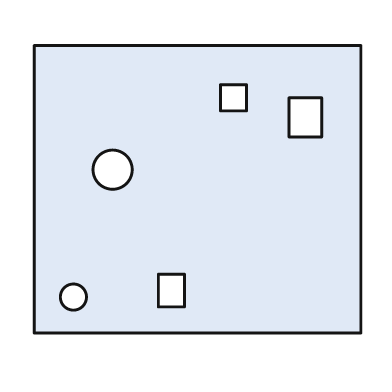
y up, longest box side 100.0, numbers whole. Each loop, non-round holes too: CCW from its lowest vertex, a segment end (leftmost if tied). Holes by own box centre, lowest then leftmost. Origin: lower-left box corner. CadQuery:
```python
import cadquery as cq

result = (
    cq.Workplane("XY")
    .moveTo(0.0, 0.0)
    .lineTo(100.0, 0.0)
    .lineTo(100.0, 88.0)
    .lineTo(0.0, 88.0)
    .close()
    .moveTo(12.0, 11.0)
    .circle(4.0)
    .moveTo(38.0, 8.0)
    .lineTo(46.0, 8.0)
    .lineTo(46.0, 18.0)
    .lineTo(38.0, 18.0)
    .close()
    .moveTo(24.0, 50.0)
    .circle(6.0)
    .moveTo(78.0, 60.0)
    .lineTo(88.0, 60.0)
    .lineTo(88.0, 72.0)
    .lineTo(78.0, 72.0)
    .close()
    .moveTo(57.0, 68.0)
    .lineTo(65.0, 68.0)
    .lineTo(65.0, 76.0)
    .lineTo(57.0, 76.0)
    .close()
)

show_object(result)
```